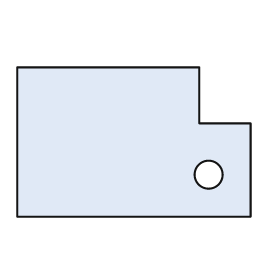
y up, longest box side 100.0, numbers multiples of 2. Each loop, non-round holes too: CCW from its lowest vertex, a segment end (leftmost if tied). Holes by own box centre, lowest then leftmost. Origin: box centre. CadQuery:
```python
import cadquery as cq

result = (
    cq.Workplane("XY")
    .moveTo(-50.0, -32.0)
    .lineTo(50.0, -32.0)
    .lineTo(50.0, 8.0)
    .lineTo(28.0, 8.0)
    .lineTo(28.0, 32.0)
    .lineTo(-50.0, 32.0)
    .close()
    .moveTo(32.0, -14.0)
    .circle(6.0)
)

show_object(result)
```